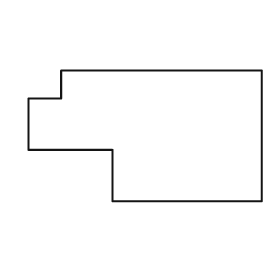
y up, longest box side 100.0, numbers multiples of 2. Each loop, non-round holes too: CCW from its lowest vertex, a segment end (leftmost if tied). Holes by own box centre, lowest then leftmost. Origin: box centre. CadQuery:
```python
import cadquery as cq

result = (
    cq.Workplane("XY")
    .moveTo(-14.0, -28.0)
    .lineTo(50.0, -28.0)
    .lineTo(50.0, 28.0)
    .lineTo(-36.0, 28.0)
    .lineTo(-36.0, 16.0)
    .lineTo(-50.0, 16.0)
    .lineTo(-50.0, -6.0)
    .lineTo(-14.0, -6.0)
    .close()
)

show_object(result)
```